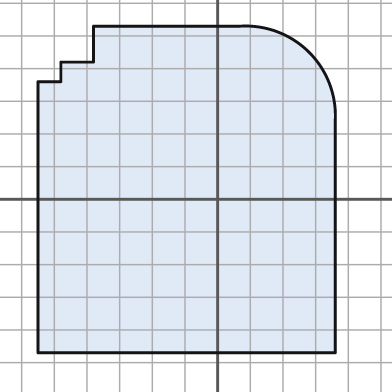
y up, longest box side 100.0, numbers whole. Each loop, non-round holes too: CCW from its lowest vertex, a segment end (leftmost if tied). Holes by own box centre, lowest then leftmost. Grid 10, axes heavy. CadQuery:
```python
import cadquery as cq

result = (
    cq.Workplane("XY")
    .moveTo(-55.0, -47.0)
    .lineTo(36.0, -47.0)
    .lineTo(36.0, 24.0)
    .threePointArc((28.0, 45.0), (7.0, 53.0))
    .lineTo(-38.0, 53.0)
    .lineTo(-38.0, 42.0)
    .lineTo(-48.0, 42.0)
    .lineTo(-48.0, 36.0)
    .lineTo(-55.0, 36.0)
    .close()
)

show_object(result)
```